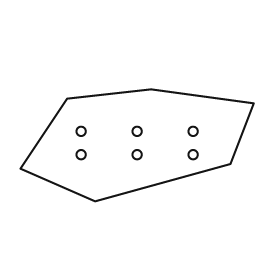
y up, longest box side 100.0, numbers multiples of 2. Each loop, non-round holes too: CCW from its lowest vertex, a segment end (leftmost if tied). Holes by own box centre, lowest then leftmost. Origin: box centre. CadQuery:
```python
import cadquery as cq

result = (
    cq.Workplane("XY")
    .moveTo(-18.0, -24.0)
    .lineTo(40.0, -8.0)
    .lineTo(50.0, 18.0)
    .lineTo(6.0, 24.0)
    .lineTo(-30.0, 20.0)
    .lineTo(-50.0, -10.0)
    .close()
    .moveTo(-24.0, -4.0)
    .circle(2.0)
    .moveTo(0.0, -4.0)
    .circle(2.0)
    .moveTo(24.0, -4.0)
    .circle(2.0)
    .moveTo(-24.0, 6.0)
    .circle(2.0)
    .moveTo(0.0, 6.0)
    .circle(2.0)
    .moveTo(24.0, 6.0)
    .circle(2.0)
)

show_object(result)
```